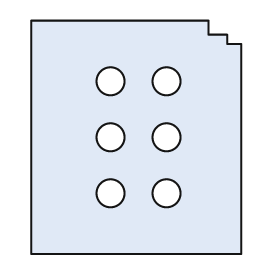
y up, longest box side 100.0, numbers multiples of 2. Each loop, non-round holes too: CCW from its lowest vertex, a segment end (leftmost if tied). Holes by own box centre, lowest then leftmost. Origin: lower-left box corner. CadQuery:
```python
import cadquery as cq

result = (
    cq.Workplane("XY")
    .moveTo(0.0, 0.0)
    .lineTo(90.0, 0.0)
    .lineTo(90.0, 90.0)
    .lineTo(84.0, 90.0)
    .lineTo(84.0, 94.0)
    .lineTo(76.0, 94.0)
    .lineTo(76.0, 100.0)
    .lineTo(0.0, 100.0)
    .close()
    .moveTo(34.0, 26.0)
    .circle(6.0)
    .moveTo(58.0, 26.0)
    .circle(6.0)
    .moveTo(34.0, 50.0)
    .circle(6.0)
    .moveTo(58.0, 50.0)
    .circle(6.0)
    .moveTo(34.0, 74.0)
    .circle(6.0)
    .moveTo(58.0, 74.0)
    .circle(6.0)
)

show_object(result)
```